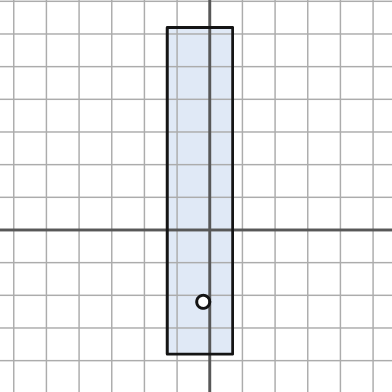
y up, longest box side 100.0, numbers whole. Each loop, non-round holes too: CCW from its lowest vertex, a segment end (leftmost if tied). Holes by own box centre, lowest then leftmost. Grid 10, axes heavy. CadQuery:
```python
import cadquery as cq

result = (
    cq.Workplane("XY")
    .moveTo(-13.0, -38.0)
    .lineTo(7.0, -38.0)
    .lineTo(7.0, 62.0)
    .lineTo(-13.0, 62.0)
    .close()
    .moveTo(-2.0, -22.0)
    .circle(2.0)
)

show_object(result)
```